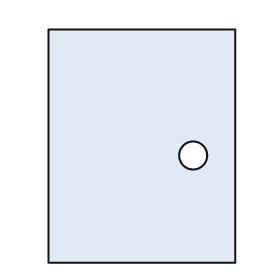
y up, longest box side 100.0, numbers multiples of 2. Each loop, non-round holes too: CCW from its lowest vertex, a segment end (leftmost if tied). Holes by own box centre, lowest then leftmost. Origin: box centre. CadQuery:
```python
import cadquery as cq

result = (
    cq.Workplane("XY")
    .moveTo(-40.0, -50.0)
    .lineTo(40.0, -50.0)
    .lineTo(40.0, 50.0)
    .lineTo(-40.0, 50.0)
    .close()
    .moveTo(22.0, -4.0)
    .circle(6.0)
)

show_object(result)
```